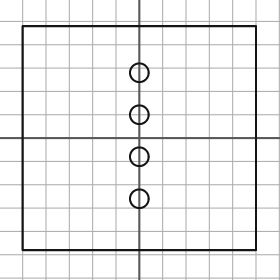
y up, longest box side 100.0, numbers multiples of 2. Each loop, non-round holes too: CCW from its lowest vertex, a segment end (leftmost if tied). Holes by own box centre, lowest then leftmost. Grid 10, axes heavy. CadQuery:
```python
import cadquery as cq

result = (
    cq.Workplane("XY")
    .moveTo(-50.0, -48.0)
    .lineTo(50.0, -48.0)
    .lineTo(50.0, 48.0)
    .lineTo(-50.0, 48.0)
    .close()
    .moveTo(0.0, -26.0)
    .circle(4.0)
    .moveTo(0.0, -8.0)
    .circle(4.0)
    .moveTo(0.0, 10.0)
    .circle(4.0)
    .moveTo(0.0, 28.0)
    .circle(4.0)
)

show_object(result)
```